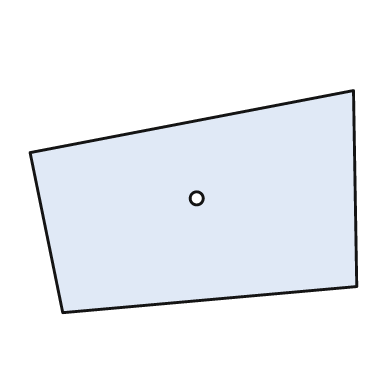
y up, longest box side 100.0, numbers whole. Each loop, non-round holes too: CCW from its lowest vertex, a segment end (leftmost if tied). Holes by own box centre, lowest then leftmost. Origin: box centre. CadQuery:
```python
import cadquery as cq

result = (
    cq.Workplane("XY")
    .moveTo(-40.0, -34.0)
    .lineTo(50.0, -26.0)
    .lineTo(49.0, 34.0)
    .lineTo(-50.0, 15.0)
    .close()
    .moveTo(1.0, 1.0)
    .circle(2.0)
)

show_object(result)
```